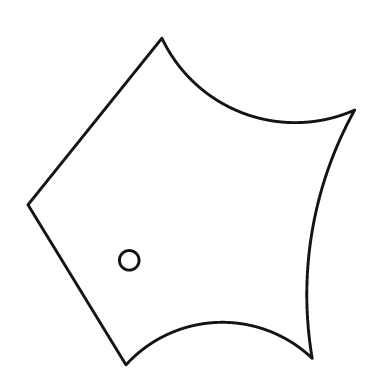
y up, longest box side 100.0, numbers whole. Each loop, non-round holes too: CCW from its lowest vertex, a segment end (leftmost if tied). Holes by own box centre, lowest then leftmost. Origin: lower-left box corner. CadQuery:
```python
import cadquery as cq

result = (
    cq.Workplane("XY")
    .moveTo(30.0, 0.0)
    .threePointArc((58.0, 13.0), (87.0, 2.0))
    .threePointArc((87.0, 41.0), (100.0, 78.0))
    .threePointArc((66.0, 77.0), (41.0, 100.0))
    .lineTo(0.0, 49.0)
    .close()
    .moveTo(31.0, 32.0)
    .circle(3.0)
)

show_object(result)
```